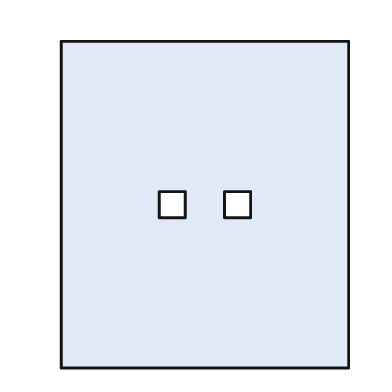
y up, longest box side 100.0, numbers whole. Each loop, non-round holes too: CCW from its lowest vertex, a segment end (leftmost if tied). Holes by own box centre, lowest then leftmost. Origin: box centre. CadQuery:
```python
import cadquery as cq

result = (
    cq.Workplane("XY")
    .moveTo(-44.0, -50.0)
    .lineTo(44.0, -50.0)
    .lineTo(44.0, 50.0)
    .lineTo(-44.0, 50.0)
    .close()
    .moveTo(-14.0, -4.0)
    .lineTo(-6.0, -4.0)
    .lineTo(-6.0, 4.0)
    .lineTo(-14.0, 4.0)
    .close()
    .moveTo(6.0, -4.0)
    .lineTo(14.0, -4.0)
    .lineTo(14.0, 4.0)
    .lineTo(6.0, 4.0)
    .close()
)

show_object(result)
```